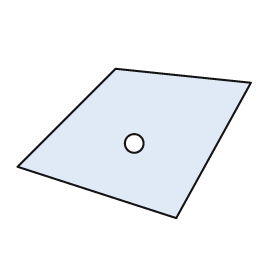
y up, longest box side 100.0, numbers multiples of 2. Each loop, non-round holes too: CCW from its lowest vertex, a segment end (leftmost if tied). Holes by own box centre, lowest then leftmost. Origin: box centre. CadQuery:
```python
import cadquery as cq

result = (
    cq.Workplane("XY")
    .moveTo(18.0, -32.0)
    .lineTo(50.0, 26.0)
    .lineTo(-8.0, 32.0)
    .lineTo(-50.0, -10.0)
    .close()
    .moveTo(0.0, 0.0)
    .circle(4.0)
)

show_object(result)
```